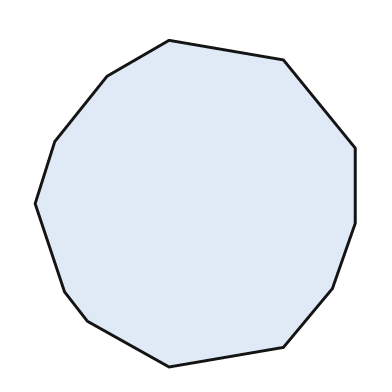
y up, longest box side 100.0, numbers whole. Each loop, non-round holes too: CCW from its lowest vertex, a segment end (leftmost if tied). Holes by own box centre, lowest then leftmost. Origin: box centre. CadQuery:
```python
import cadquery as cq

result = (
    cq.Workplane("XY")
    .moveTo(-8.0, -50.0)
    .lineTo(27.0, -44.0)
    .lineTo(42.0, -26.0)
    .lineTo(49.0, -6.0)
    .lineTo(49.0, 17.0)
    .lineTo(27.0, 44.0)
    .lineTo(-8.0, 50.0)
    .lineTo(-27.0, 39.0)
    .lineTo(-43.0, 19.0)
    .lineTo(-49.0, 0.0)
    .lineTo(-40.0, -27.0)
    .lineTo(-33.0, -36.0)
    .close()
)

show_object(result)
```